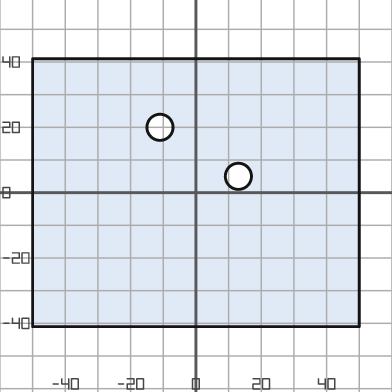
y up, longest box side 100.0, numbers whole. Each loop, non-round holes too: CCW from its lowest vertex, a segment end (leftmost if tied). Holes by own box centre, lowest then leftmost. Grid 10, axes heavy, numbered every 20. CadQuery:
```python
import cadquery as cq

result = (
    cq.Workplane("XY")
    .moveTo(-50.0, -41.0)
    .lineTo(50.0, -41.0)
    .lineTo(50.0, 41.0)
    .lineTo(-50.0, 41.0)
    .close()
    .moveTo(13.0, 5.0)
    .circle(4.0)
    .moveTo(-11.0, 20.0)
    .circle(4.0)
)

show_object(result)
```